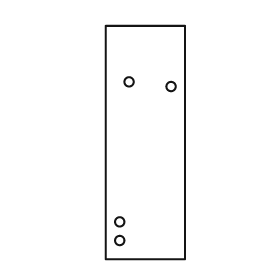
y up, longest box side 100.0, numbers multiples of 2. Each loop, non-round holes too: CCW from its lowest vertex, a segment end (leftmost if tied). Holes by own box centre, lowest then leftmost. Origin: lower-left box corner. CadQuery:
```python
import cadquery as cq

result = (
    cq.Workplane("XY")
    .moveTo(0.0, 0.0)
    .lineTo(34.0, 0.0)
    .lineTo(34.0, 100.0)
    .lineTo(0.0, 100.0)
    .close()
    .moveTo(6.0, 8.0)
    .circle(2.0)
    .moveTo(6.0, 16.0)
    .circle(2.0)
    .moveTo(28.0, 74.0)
    .circle(2.0)
    .moveTo(10.0, 76.0)
    .circle(2.0)
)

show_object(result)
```